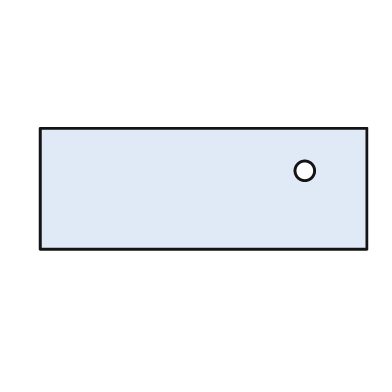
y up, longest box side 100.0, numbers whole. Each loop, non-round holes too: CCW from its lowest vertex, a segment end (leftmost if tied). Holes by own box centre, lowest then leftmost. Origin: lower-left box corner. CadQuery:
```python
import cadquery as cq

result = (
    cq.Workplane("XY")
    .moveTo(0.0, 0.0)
    .lineTo(100.0, 0.0)
    .lineTo(100.0, 37.0)
    .lineTo(0.0, 37.0)
    .close()
    .moveTo(81.0, 24.0)
    .circle(3.0)
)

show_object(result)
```